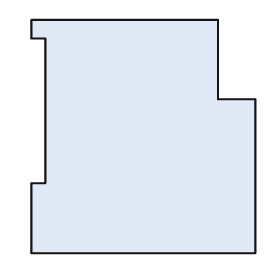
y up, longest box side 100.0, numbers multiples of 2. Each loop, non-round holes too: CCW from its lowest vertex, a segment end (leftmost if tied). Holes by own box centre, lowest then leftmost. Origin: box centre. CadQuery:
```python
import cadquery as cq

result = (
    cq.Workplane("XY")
    .moveTo(-48.0, -50.0)
    .lineTo(48.0, -50.0)
    .lineTo(48.0, 16.0)
    .lineTo(32.0, 16.0)
    .lineTo(32.0, 50.0)
    .lineTo(-48.0, 50.0)
    .lineTo(-48.0, 42.0)
    .lineTo(-42.0, 42.0)
    .lineTo(-42.0, -20.0)
    .lineTo(-48.0, -20.0)
    .close()
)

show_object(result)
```